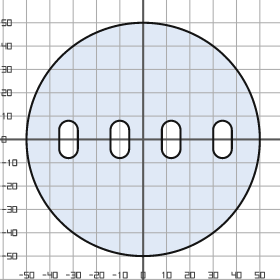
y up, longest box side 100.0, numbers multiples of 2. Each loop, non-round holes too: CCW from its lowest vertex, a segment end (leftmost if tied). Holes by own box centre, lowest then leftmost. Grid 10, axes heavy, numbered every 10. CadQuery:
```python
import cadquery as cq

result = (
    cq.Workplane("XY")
    .moveTo(0.0, 0.0)
    .circle(50.0)
    .moveTo(-36.0, -4.0)
    .threePointArc((-32.0, -8.0), (-28.0, -4.0))
    .lineTo(-28.0, 4.0)
    .threePointArc((-32.0, 8.0), (-36.0, 4.0))
    .close()
    .moveTo(-14.0, -4.0)
    .threePointArc((-10.0, -8.0), (-6.0, -4.0))
    .lineTo(-6.0, 4.0)
    .threePointArc((-10.0, 8.0), (-14.0, 4.0))
    .close()
    .moveTo(8.0, -4.0)
    .threePointArc((12.0, -8.0), (16.0, -4.0))
    .lineTo(16.0, 4.0)
    .threePointArc((12.0, 8.0), (8.0, 4.0))
    .close()
    .moveTo(30.0, -4.0)
    .threePointArc((34.0, -8.0), (38.0, -4.0))
    .lineTo(38.0, 4.0)
    .threePointArc((34.0, 8.0), (30.0, 4.0))
    .close()
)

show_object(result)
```